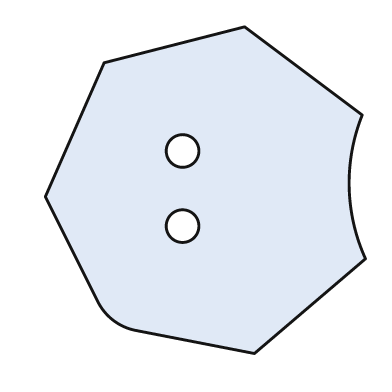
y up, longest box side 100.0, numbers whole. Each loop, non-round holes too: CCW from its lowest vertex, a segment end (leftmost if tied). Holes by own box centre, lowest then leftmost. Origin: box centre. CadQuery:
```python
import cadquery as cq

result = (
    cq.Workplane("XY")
    .moveTo(15.0, -50.0)
    .lineTo(49.0, -21.0)
    .threePointArc((44.0, 1.0), (48.0, 23.0))
    .lineTo(12.0, 50.0)
    .lineTo(-31.0, 39.0)
    .lineTo(-49.0, -2.0)
    .lineTo(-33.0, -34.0)
    .threePointArc((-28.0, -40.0), (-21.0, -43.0))
    .close()
    .moveTo(-7.0, -11.0)
    .circle(5.0)
    .moveTo(-7.0, 12.0)
    .circle(5.0)
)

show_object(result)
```